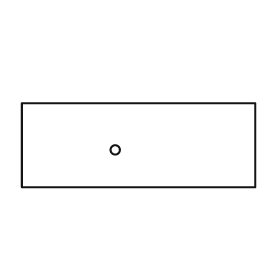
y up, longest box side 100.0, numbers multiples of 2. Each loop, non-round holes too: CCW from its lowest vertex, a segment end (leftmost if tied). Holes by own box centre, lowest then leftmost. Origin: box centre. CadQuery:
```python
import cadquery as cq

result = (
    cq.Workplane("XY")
    .moveTo(-50.0, -18.0)
    .lineTo(50.0, -18.0)
    .lineTo(50.0, 18.0)
    .lineTo(-50.0, 18.0)
    .close()
    .moveTo(-10.0, -2.0)
    .circle(2.0)
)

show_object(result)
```